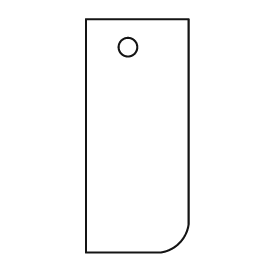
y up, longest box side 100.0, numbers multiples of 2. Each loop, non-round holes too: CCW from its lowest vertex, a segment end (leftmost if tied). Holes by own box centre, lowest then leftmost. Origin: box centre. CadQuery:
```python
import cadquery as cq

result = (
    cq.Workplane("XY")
    .moveTo(-22.0, -50.0)
    .lineTo(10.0, -50.0)
    .threePointArc((18.0, -46.0), (22.0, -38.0))
    .lineTo(22.0, 50.0)
    .lineTo(-22.0, 50.0)
    .close()
    .moveTo(-4.0, 38.0)
    .circle(4.0)
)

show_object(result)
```